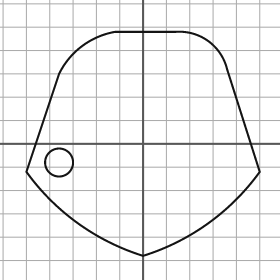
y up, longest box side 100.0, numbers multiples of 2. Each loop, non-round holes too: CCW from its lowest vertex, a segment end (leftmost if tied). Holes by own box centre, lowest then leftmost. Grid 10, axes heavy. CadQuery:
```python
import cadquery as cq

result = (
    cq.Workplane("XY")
    .moveTo(0.0, -48.0)
    .threePointArc((28.0, -34.0), (50.0, -12.0))
    .lineTo(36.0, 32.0)
    .threePointArc((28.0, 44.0), (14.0, 48.0))
    .lineTo(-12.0, 48.0)
    .threePointArc((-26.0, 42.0), (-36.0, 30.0))
    .lineTo(-50.0, -12.0)
    .threePointArc((-28.0, -34.0), (0.0, -48.0))
    .close()
    .moveTo(-36.0, -8.0)
    .circle(6.0)
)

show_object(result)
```